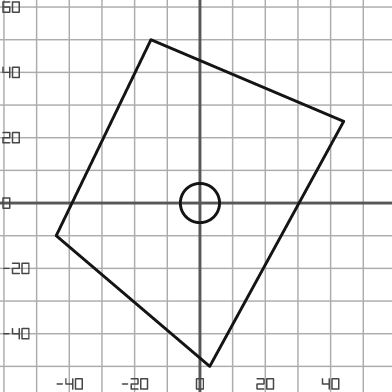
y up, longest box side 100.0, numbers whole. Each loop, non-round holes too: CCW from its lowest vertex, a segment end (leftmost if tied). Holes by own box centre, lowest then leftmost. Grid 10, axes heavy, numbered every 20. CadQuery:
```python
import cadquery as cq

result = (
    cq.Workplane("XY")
    .moveTo(3.0, -50.0)
    .lineTo(44.0, 25.0)
    .lineTo(-15.0, 50.0)
    .lineTo(-44.0, -10.0)
    .close()
    .moveTo(0.0, 0.0)
    .circle(6.0)
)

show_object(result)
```